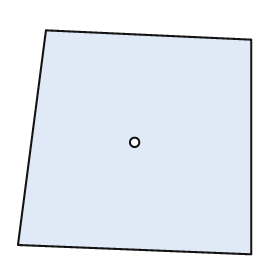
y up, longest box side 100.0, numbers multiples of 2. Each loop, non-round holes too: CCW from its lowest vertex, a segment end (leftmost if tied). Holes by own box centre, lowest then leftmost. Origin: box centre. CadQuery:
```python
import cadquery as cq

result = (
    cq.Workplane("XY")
    .moveTo(50.0, -48.0)
    .lineTo(50.0, 44.0)
    .lineTo(-38.0, 48.0)
    .lineTo(-50.0, -44.0)
    .close()
    .moveTo(0.0, 0.0)
    .circle(2.0)
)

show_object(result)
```